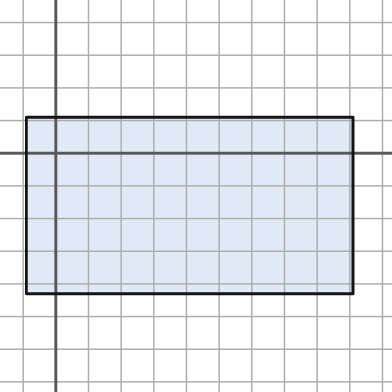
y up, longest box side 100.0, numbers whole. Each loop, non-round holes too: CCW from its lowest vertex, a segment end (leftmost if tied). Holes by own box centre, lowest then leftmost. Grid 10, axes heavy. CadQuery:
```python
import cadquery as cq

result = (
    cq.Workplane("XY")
    .moveTo(-9.0, -43.0)
    .lineTo(91.0, -43.0)
    .lineTo(91.0, 11.0)
    .lineTo(-9.0, 11.0)
    .close()
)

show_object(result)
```